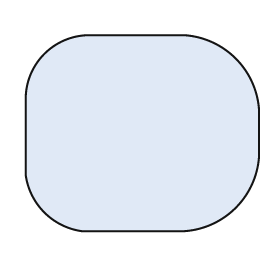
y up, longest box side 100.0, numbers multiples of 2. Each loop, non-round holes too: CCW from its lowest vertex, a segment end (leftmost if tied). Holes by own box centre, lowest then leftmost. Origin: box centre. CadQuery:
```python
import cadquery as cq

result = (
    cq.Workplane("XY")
    .moveTo(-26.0, -42.0)
    .lineTo(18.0, -42.0)
    .threePointArc((40.0, -32.0), (50.0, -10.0))
    .lineTo(50.0, 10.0)
    .threePointArc((40.0, 32.0), (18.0, 42.0))
    .lineTo(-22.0, 42.0)
    .threePointArc((-42.0, 34.0), (-50.0, 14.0))
    .lineTo(-50.0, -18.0)
    .threePointArc((-42.0, -34.0), (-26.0, -42.0))
    .close()
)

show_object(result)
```